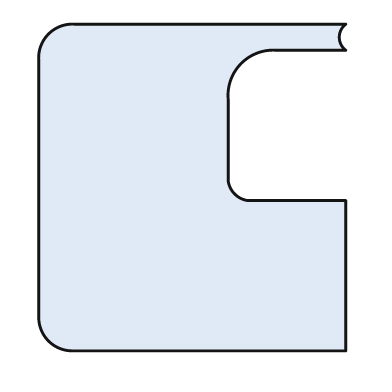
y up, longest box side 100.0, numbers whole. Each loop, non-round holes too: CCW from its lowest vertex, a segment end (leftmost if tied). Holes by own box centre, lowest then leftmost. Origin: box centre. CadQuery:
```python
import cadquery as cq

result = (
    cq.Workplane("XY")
    .moveTo(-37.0, -50.0)
    .lineTo(47.0, -50.0)
    .lineTo(47.0, -4.0)
    .lineTo(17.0, -4.0)
    .threePointArc((13.0, -2.0), (11.0, 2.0))
    .lineTo(11.0, 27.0)
    .threePointArc((15.0, 38.0), (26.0, 42.0))
    .lineTo(47.0, 42.0)
    .threePointArc((45.0, 46.0), (47.0, 50.0))
    .lineTo(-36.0, 50.0)
    .threePointArc((-44.0, 47.0), (-47.0, 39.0))
    .lineTo(-47.0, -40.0)
    .threePointArc((-44.0, -47.0), (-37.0, -50.0))
    .close()
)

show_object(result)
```